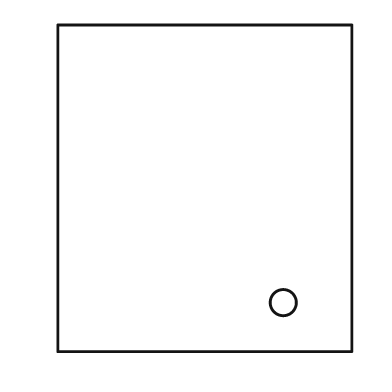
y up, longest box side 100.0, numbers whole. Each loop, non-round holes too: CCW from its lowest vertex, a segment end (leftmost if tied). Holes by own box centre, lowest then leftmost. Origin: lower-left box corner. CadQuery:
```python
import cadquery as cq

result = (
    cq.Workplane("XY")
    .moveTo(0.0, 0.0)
    .lineTo(90.0, 0.0)
    .lineTo(90.0, 100.0)
    .lineTo(0.0, 100.0)
    .close()
    .moveTo(69.0, 15.0)
    .circle(4.0)
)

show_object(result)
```